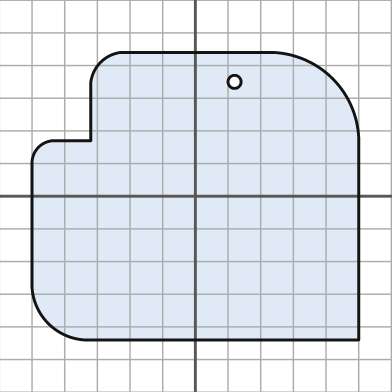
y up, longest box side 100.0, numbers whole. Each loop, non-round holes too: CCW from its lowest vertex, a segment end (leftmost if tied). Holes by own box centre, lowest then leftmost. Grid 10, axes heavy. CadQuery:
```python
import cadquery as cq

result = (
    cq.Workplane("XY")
    .moveTo(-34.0, -44.0)
    .lineTo(50.0, -44.0)
    .lineTo(50.0, 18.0)
    .threePointArc((42.0, 36.0), (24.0, 44.0))
    .lineTo(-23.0, 44.0)
    .threePointArc((-29.0, 41.0), (-32.0, 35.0))
    .lineTo(-32.0, 17.0)
    .lineTo(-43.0, 17.0)
    .threePointArc((-48.0, 15.0), (-50.0, 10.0))
    .lineTo(-50.0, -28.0)
    .threePointArc((-45.0, -39.0), (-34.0, -44.0))
    .close()
    .moveTo(12.0, 35.0)
    .circle(2.0)
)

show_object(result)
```